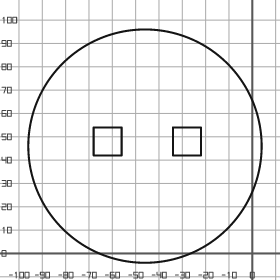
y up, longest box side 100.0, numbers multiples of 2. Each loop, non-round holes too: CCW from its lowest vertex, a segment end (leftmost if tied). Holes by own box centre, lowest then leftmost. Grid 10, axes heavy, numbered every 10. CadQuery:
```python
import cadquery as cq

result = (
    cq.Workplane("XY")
    .moveTo(-46.0, 46.0)
    .circle(50.0)
    .moveTo(-68.0, 42.0)
    .lineTo(-56.0, 42.0)
    .lineTo(-56.0, 54.0)
    .lineTo(-68.0, 54.0)
    .close()
    .moveTo(-34.0, 42.0)
    .lineTo(-22.0, 42.0)
    .lineTo(-22.0, 54.0)
    .lineTo(-34.0, 54.0)
    .close()
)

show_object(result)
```